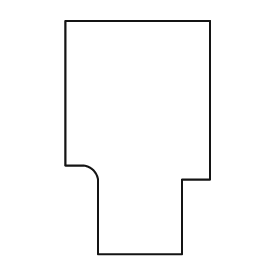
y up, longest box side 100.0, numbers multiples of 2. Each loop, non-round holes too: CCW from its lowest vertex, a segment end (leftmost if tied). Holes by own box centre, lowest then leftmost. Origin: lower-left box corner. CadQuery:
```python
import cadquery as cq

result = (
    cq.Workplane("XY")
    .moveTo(14.0, 0.0)
    .lineTo(50.0, 0.0)
    .lineTo(50.0, 32.0)
    .lineTo(62.0, 32.0)
    .lineTo(62.0, 100.0)
    .lineTo(0.0, 100.0)
    .lineTo(0.0, 38.0)
    .lineTo(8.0, 38.0)
    .threePointArc((12.0, 36.0), (14.0, 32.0))
    .close()
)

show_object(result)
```